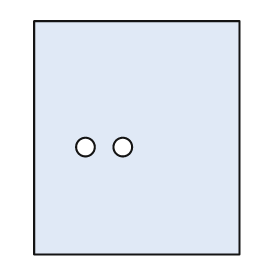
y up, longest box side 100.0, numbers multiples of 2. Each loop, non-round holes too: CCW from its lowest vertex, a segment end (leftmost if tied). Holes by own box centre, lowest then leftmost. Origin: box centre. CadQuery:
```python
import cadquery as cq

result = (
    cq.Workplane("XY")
    .moveTo(-44.0, -50.0)
    .lineTo(44.0, -50.0)
    .lineTo(44.0, 50.0)
    .lineTo(-44.0, 50.0)
    .close()
    .moveTo(-22.0, -4.0)
    .circle(4.0)
    .moveTo(-6.0, -4.0)
    .circle(4.0)
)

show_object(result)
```